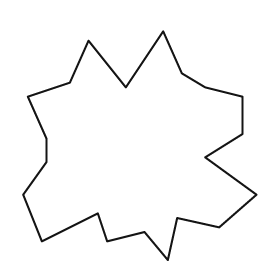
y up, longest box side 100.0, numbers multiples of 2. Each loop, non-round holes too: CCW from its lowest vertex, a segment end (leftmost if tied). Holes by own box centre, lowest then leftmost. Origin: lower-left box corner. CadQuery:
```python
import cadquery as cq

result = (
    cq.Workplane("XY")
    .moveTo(62.0, 0.0)
    .lineTo(66.0, 18.0)
    .lineTo(84.0, 14.0)
    .lineTo(100.0, 28.0)
    .lineTo(78.0, 44.0)
    .lineTo(94.0, 54.0)
    .lineTo(94.0, 70.0)
    .lineTo(78.0, 74.0)
    .lineTo(68.0, 80.0)
    .lineTo(60.0, 98.0)
    .lineTo(44.0, 74.0)
    .lineTo(28.0, 94.0)
    .lineTo(20.0, 76.0)
    .lineTo(2.0, 70.0)
    .lineTo(10.0, 52.0)
    .lineTo(10.0, 42.0)
    .lineTo(0.0, 28.0)
    .lineTo(8.0, 8.0)
    .lineTo(32.0, 20.0)
    .lineTo(36.0, 8.0)
    .lineTo(52.0, 12.0)
    .close()
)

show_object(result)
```